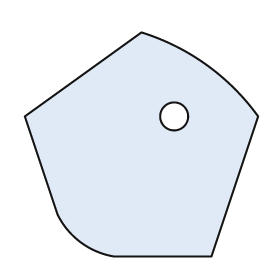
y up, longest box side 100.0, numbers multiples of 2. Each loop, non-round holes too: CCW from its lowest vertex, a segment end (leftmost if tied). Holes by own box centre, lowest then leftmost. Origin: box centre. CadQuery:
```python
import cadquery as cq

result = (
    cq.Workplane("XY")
    .moveTo(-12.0, -48.0)
    .lineTo(30.0, -48.0)
    .lineTo(50.0, 12.0)
    .threePointArc((28.0, 34.0), (0.0, 48.0))
    .lineTo(-50.0, 12.0)
    .lineTo(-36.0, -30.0)
    .threePointArc((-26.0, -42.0), (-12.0, -48.0))
    .close()
    .moveTo(14.0, 12.0)
    .circle(6.0)
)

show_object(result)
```